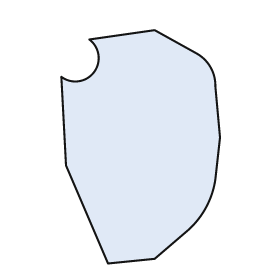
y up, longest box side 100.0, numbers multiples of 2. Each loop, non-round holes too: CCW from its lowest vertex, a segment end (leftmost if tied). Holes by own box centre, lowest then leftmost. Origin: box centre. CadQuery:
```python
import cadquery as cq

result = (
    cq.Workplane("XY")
    .moveTo(-14.0, -50.0)
    .lineTo(6.0, -48.0)
    .lineTo(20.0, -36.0)
    .threePointArc((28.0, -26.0), (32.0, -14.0))
    .lineTo(34.0, 4.0)
    .lineTo(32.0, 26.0)
    .threePointArc((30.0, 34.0), (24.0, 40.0))
    .lineTo(6.0, 50.0)
    .lineTo(-22.0, 46.0)
    .threePointArc((-20.0, 32.0), (-34.0, 30.0))
    .lineTo(-32.0, -8.0)
    .close()
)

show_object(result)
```